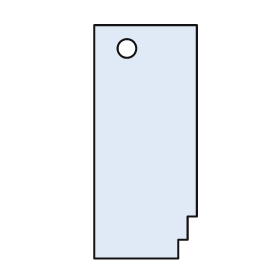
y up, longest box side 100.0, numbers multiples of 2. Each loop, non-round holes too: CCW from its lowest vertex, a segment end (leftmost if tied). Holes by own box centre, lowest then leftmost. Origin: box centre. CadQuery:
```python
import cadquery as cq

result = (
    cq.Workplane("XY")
    .moveTo(-22.0, -50.0)
    .lineTo(14.0, -50.0)
    .lineTo(14.0, -42.0)
    .lineTo(18.0, -42.0)
    .lineTo(18.0, -32.0)
    .lineTo(22.0, -32.0)
    .lineTo(22.0, 50.0)
    .lineTo(-22.0, 50.0)
    .close()
    .moveTo(-8.0, 40.0)
    .circle(4.0)
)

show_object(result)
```